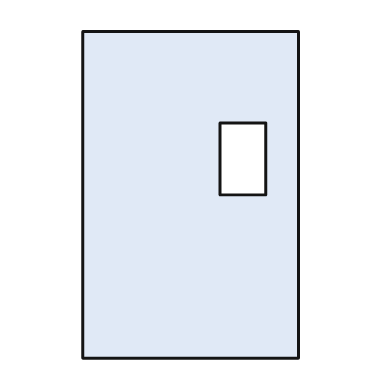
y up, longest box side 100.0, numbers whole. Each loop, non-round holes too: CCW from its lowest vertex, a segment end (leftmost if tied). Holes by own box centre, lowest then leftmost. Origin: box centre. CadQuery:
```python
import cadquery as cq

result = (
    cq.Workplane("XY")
    .moveTo(-33.0, -50.0)
    .lineTo(33.0, -50.0)
    .lineTo(33.0, 50.0)
    .lineTo(-33.0, 50.0)
    .close()
    .moveTo(9.0, 0.0)
    .lineTo(23.0, 0.0)
    .lineTo(23.0, 22.0)
    .lineTo(9.0, 22.0)
    .close()
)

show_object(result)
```